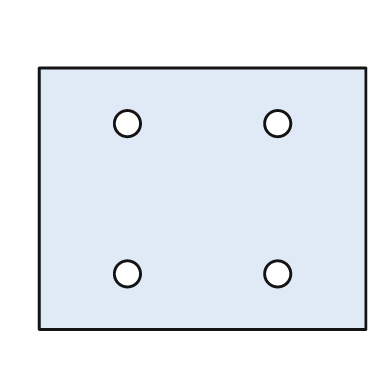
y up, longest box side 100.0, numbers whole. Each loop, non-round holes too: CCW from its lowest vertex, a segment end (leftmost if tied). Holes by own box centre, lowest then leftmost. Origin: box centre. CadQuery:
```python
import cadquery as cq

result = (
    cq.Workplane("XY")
    .moveTo(-50.0, -40.0)
    .lineTo(50.0, -40.0)
    .lineTo(50.0, 40.0)
    .lineTo(-50.0, 40.0)
    .close()
    .moveTo(-23.0, -23.0)
    .circle(4.0)
    .moveTo(23.0, -23.0)
    .circle(4.0)
    .moveTo(-23.0, 23.0)
    .circle(4.0)
    .moveTo(23.0, 23.0)
    .circle(4.0)
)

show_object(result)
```